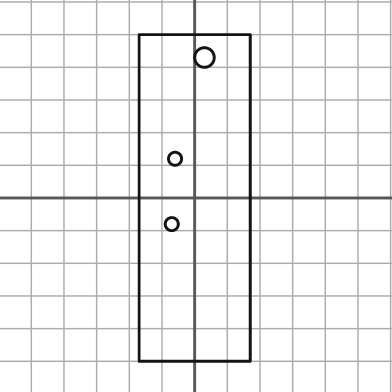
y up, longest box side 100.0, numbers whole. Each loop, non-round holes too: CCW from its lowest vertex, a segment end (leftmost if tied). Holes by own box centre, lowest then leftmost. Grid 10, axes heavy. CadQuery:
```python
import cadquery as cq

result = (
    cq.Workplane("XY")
    .moveTo(-17.0, -50.0)
    .lineTo(17.0, -50.0)
    .lineTo(17.0, 50.0)
    .lineTo(-17.0, 50.0)
    .close()
    .moveTo(-7.0, -8.0)
    .circle(2.0)
    .moveTo(-6.0, 12.0)
    .circle(2.0)
    .moveTo(3.0, 43.0)
    .circle(3.0)
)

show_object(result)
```